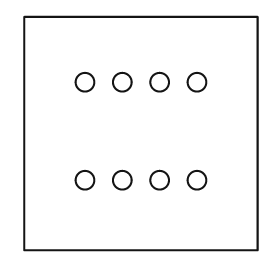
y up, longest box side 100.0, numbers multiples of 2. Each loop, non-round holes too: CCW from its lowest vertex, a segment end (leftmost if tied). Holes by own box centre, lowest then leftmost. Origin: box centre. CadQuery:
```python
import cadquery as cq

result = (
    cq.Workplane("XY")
    .moveTo(-50.0, -50.0)
    .lineTo(50.0, -50.0)
    .lineTo(50.0, 50.0)
    .lineTo(-50.0, 50.0)
    .close()
    .moveTo(-24.0, -20.0)
    .circle(4.0)
    .moveTo(-8.0, -20.0)
    .circle(4.0)
    .moveTo(8.0, -20.0)
    .circle(4.0)
    .moveTo(24.0, -20.0)
    .circle(4.0)
    .moveTo(-24.0, 22.0)
    .circle(4.0)
    .moveTo(-8.0, 22.0)
    .circle(4.0)
    .moveTo(8.0, 22.0)
    .circle(4.0)
    .moveTo(24.0, 22.0)
    .circle(4.0)
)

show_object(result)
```